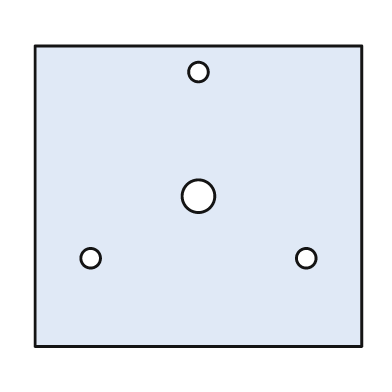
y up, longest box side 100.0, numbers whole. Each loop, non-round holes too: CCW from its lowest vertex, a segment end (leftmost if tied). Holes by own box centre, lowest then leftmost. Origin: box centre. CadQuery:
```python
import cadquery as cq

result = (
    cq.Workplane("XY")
    .moveTo(-50.0, -46.0)
    .lineTo(50.0, -46.0)
    .lineTo(50.0, 46.0)
    .lineTo(-50.0, 46.0)
    .close()
    .moveTo(-33.0, -19.0)
    .circle(3.0)
    .moveTo(33.0, -19.0)
    .circle(3.0)
    .moveTo(0.0, 0.0)
    .circle(5.0)
    .moveTo(0.0, 38.0)
    .circle(3.0)
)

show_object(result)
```